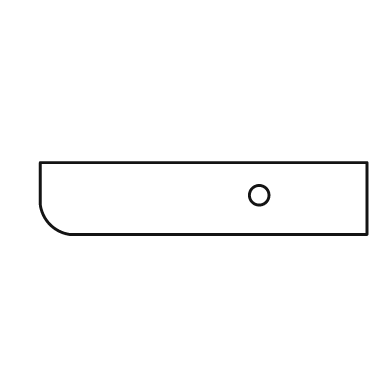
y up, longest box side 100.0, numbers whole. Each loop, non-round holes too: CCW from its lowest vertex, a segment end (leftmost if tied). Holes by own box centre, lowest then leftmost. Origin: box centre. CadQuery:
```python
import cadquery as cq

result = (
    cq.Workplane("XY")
    .moveTo(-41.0, -11.0)
    .lineTo(50.0, -11.0)
    .lineTo(50.0, 11.0)
    .lineTo(-50.0, 11.0)
    .lineTo(-50.0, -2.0)
    .threePointArc((-47.0, -8.0), (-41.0, -11.0))
    .close()
    .moveTo(17.0, 1.0)
    .circle(3.0)
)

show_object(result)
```